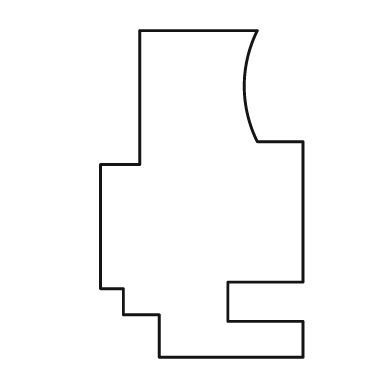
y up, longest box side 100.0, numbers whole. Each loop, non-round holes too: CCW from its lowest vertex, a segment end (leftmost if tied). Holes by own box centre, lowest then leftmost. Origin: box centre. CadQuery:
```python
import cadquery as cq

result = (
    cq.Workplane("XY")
    .moveTo(-13.0, -50.0)
    .lineTo(31.0, -50.0)
    .lineTo(31.0, -39.0)
    .lineTo(8.0, -39.0)
    .lineTo(8.0, -27.0)
    .lineTo(31.0, -27.0)
    .lineTo(31.0, 16.0)
    .lineTo(17.0, 16.0)
    .threePointArc((13.0, 33.0), (17.0, 50.0))
    .lineTo(-19.0, 50.0)
    .lineTo(-19.0, 9.0)
    .lineTo(-31.0, 9.0)
    .lineTo(-31.0, -29.0)
    .lineTo(-24.0, -29.0)
    .lineTo(-24.0, -37.0)
    .lineTo(-13.0, -37.0)
    .close()
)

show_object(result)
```